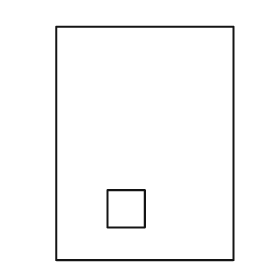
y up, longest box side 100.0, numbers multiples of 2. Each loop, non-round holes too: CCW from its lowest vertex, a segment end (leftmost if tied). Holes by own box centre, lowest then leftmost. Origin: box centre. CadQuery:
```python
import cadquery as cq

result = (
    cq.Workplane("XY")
    .moveTo(-38.0, -50.0)
    .lineTo(38.0, -50.0)
    .lineTo(38.0, 50.0)
    .lineTo(-38.0, 50.0)
    .close()
    .moveTo(-16.0, -36.0)
    .lineTo(0.0, -36.0)
    .lineTo(0.0, -20.0)
    .lineTo(-16.0, -20.0)
    .close()
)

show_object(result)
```